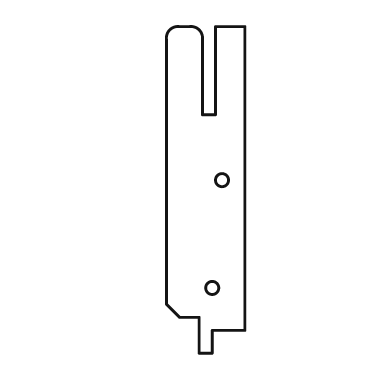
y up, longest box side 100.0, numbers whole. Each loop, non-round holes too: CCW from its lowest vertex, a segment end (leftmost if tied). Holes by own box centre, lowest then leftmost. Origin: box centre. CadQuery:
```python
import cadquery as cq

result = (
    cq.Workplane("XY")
    .moveTo(-2.0, -50.0)
    .lineTo(2.0, -50.0)
    .lineTo(2.0, -43.0)
    .lineTo(12.0, -43.0)
    .lineTo(12.0, 50.0)
    .lineTo(3.0, 50.0)
    .lineTo(3.0, 23.0)
    .lineTo(-1.0, 23.0)
    .lineTo(-1.0, 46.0)
    .threePointArc((-2.0, 49.0), (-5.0, 50.0))
    .lineTo(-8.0, 50.0)
    .threePointArc((-11.0, 49.0), (-12.0, 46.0))
    .lineTo(-12.0, -35.0)
    .lineTo(-8.0, -39.0)
    .lineTo(-2.0, -39.0)
    .close()
    .moveTo(2.0, -30.0)
    .circle(2.0)
    .moveTo(5.0, 3.0)
    .circle(2.0)
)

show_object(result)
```